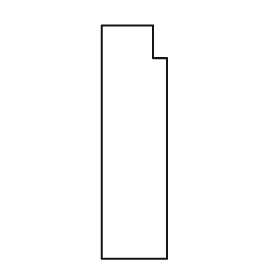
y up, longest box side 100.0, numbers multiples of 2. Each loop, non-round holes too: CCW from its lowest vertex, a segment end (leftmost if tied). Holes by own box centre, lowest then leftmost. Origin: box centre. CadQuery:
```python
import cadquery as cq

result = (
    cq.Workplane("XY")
    .moveTo(-14.0, -50.0)
    .lineTo(14.0, -50.0)
    .lineTo(14.0, 36.0)
    .lineTo(8.0, 36.0)
    .lineTo(8.0, 50.0)
    .lineTo(-14.0, 50.0)
    .close()
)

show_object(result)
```